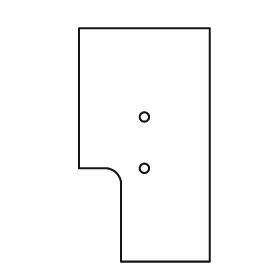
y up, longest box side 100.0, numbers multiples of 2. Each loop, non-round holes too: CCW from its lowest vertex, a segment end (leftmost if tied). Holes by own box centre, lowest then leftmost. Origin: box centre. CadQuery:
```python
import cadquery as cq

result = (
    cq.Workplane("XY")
    .moveTo(-10.0, -50.0)
    .lineTo(28.0, -50.0)
    .lineTo(28.0, 50.0)
    .lineTo(-28.0, 50.0)
    .lineTo(-28.0, -10.0)
    .lineTo(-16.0, -10.0)
    .threePointArc((-12.0, -12.0), (-10.0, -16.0))
    .close()
    .moveTo(0.0, -10.0)
    .circle(2.0)
    .moveTo(0.0, 12.0)
    .circle(2.0)
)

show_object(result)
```